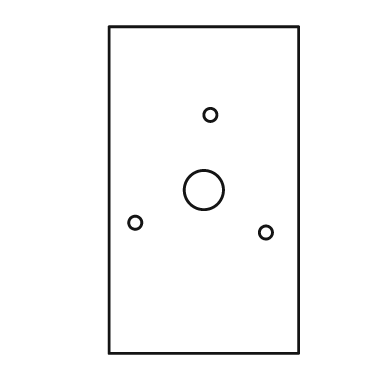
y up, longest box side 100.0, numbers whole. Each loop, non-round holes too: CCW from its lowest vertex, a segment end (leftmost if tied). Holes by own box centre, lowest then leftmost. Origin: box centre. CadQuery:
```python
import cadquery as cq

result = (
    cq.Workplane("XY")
    .moveTo(-29.0, -50.0)
    .lineTo(29.0, -50.0)
    .lineTo(29.0, 50.0)
    .lineTo(-29.0, 50.0)
    .close()
    .moveTo(19.0, -13.0)
    .circle(2.0)
    .moveTo(-21.0, -10.0)
    .circle(2.0)
    .moveTo(0.0, 0.0)
    .circle(6.0)
    .moveTo(2.0, 23.0)
    .circle(2.0)
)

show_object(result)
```